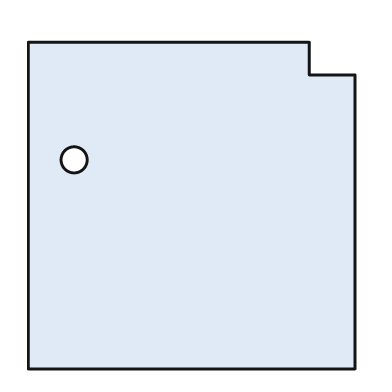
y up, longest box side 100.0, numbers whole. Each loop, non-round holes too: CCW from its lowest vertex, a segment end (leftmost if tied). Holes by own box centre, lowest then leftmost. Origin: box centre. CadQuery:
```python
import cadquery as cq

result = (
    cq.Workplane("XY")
    .moveTo(-50.0, -50.0)
    .lineTo(50.0, -50.0)
    .lineTo(50.0, 40.0)
    .lineTo(36.0, 40.0)
    .lineTo(36.0, 50.0)
    .lineTo(-50.0, 50.0)
    .close()
    .moveTo(-36.0, 14.0)
    .circle(4.0)
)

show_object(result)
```